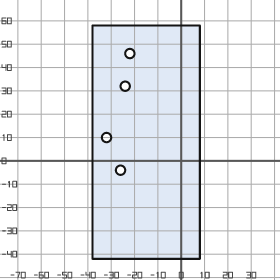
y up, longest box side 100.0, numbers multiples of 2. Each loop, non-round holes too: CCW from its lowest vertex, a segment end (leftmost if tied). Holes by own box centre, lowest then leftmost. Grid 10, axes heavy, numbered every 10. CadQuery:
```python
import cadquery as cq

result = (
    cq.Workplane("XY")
    .moveTo(-38.0, -42.0)
    .lineTo(8.0, -42.0)
    .lineTo(8.0, 58.0)
    .lineTo(-38.0, 58.0)
    .close()
    .moveTo(-26.0, -4.0)
    .circle(2.0)
    .moveTo(-32.0, 10.0)
    .circle(2.0)
    .moveTo(-24.0, 32.0)
    .circle(2.0)
    .moveTo(-22.0, 46.0)
    .circle(2.0)
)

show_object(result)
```